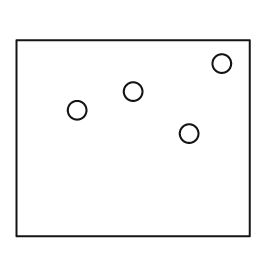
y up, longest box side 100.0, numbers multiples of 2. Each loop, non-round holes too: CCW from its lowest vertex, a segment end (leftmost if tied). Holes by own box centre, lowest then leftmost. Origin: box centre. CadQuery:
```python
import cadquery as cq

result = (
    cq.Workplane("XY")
    .moveTo(-50.0, -42.0)
    .lineTo(50.0, -42.0)
    .lineTo(50.0, 42.0)
    .lineTo(-50.0, 42.0)
    .close()
    .moveTo(24.0, 2.0)
    .circle(4.0)
    .moveTo(-24.0, 12.0)
    .circle(4.0)
    .moveTo(0.0, 20.0)
    .circle(4.0)
    .moveTo(38.0, 32.0)
    .circle(4.0)
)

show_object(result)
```